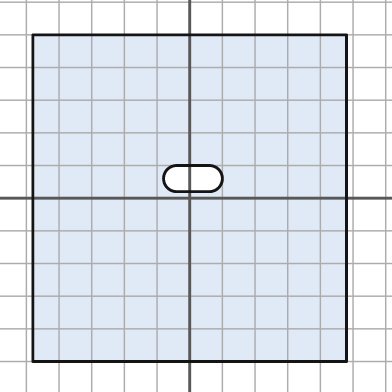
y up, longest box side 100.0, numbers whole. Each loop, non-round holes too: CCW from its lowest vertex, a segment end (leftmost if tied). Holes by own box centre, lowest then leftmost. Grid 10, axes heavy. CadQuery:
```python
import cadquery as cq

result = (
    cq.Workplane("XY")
    .moveTo(-48.0, -50.0)
    .lineTo(48.0, -50.0)
    .lineTo(48.0, 50.0)
    .lineTo(-48.0, 50.0)
    .close()
    .moveTo(-4.0, 2.0)
    .lineTo(6.0, 2.0)
    .threePointArc((10.0, 6.0), (6.0, 10.0))
    .lineTo(-4.0, 10.0)
    .threePointArc((-8.0, 6.0), (-4.0, 2.0))
    .close()
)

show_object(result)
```